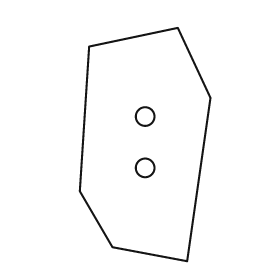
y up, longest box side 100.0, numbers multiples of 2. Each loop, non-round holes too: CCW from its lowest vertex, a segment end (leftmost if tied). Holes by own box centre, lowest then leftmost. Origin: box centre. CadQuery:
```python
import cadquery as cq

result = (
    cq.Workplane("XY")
    .moveTo(18.0, -50.0)
    .lineTo(28.0, 20.0)
    .lineTo(14.0, 50.0)
    .lineTo(-24.0, 42.0)
    .lineTo(-28.0, -20.0)
    .lineTo(-14.0, -44.0)
    .close()
    .moveTo(0.0, -10.0)
    .circle(4.0)
    .moveTo(0.0, 12.0)
    .circle(4.0)
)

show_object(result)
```